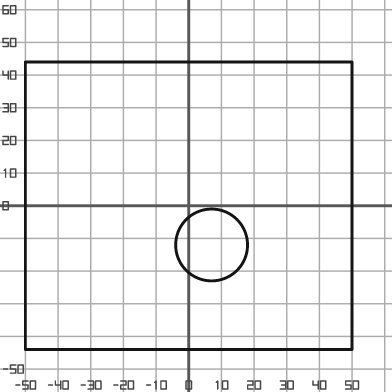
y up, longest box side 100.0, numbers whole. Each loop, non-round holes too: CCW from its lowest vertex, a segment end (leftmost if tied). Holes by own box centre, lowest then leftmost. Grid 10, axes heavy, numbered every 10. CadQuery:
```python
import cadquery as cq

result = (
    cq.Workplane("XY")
    .moveTo(-50.0, -44.0)
    .lineTo(50.0, -44.0)
    .lineTo(50.0, 44.0)
    .lineTo(-50.0, 44.0)
    .close()
    .moveTo(7.0, -12.0)
    .circle(11.0)
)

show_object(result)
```